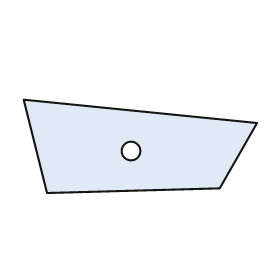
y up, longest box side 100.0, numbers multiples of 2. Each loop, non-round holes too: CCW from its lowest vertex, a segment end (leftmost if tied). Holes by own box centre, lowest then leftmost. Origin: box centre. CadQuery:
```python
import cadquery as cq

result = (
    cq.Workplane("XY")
    .moveTo(-40.0, -20.0)
    .lineTo(34.0, -18.0)
    .lineTo(50.0, 10.0)
    .lineTo(-50.0, 20.0)
    .close()
    .moveTo(-4.0, -2.0)
    .circle(4.0)
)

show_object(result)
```